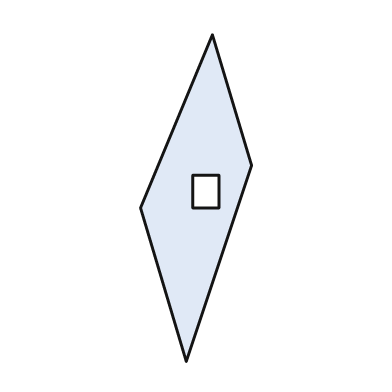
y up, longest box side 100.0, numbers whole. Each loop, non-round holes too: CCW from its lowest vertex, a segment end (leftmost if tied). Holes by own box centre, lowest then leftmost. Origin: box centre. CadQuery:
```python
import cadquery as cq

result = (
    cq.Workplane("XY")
    .moveTo(-3.0, -50.0)
    .lineTo(17.0, 10.0)
    .lineTo(5.0, 50.0)
    .lineTo(-17.0, -3.0)
    .close()
    .moveTo(-1.0, -3.0)
    .lineTo(7.0, -3.0)
    .lineTo(7.0, 7.0)
    .lineTo(-1.0, 7.0)
    .close()
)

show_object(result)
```